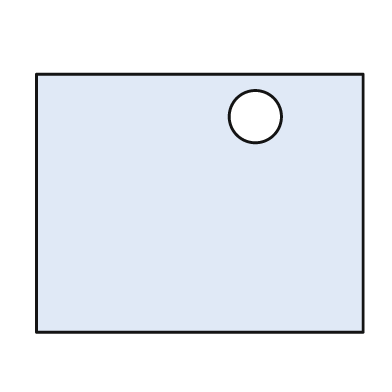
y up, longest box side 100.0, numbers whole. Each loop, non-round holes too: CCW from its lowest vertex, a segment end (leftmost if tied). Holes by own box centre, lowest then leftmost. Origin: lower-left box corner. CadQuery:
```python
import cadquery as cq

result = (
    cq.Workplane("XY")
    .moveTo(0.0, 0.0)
    .lineTo(100.0, 0.0)
    .lineTo(100.0, 79.0)
    .lineTo(0.0, 79.0)
    .close()
    .moveTo(67.0, 66.0)
    .circle(8.0)
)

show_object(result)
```